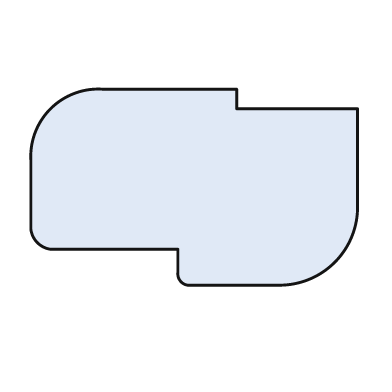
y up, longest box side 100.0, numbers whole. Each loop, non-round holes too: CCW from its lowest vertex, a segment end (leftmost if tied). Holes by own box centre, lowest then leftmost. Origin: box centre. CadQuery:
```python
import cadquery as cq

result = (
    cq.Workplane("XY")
    .moveTo(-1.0, -30.0)
    .lineTo(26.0, -30.0)
    .threePointArc((43.0, -23.0), (50.0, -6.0))
    .lineTo(50.0, 24.0)
    .lineTo(13.0, 24.0)
    .lineTo(13.0, 30.0)
    .lineTo(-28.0, 30.0)
    .threePointArc((-44.0, 24.0), (-50.0, 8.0))
    .lineTo(-50.0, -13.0)
    .threePointArc((-48.0, -17.0), (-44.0, -19.0))
    .lineTo(-5.0, -19.0)
    .lineTo(-5.0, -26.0)
    .threePointArc((-4.0, -29.0), (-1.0, -30.0))
    .close()
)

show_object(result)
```